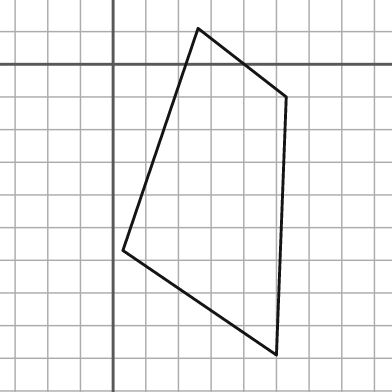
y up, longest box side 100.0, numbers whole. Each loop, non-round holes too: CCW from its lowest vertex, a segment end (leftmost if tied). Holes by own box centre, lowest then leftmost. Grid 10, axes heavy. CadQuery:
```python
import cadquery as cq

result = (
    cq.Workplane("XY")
    .moveTo(50.0, -89.0)
    .lineTo(53.0, -10.0)
    .lineTo(26.0, 11.0)
    .lineTo(3.0, -57.0)
    .close()
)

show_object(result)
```